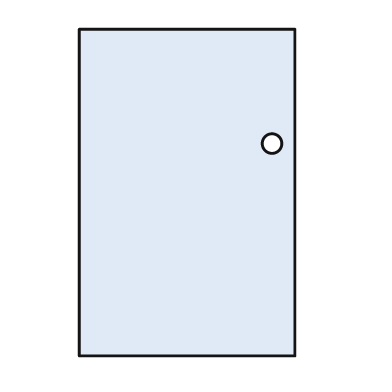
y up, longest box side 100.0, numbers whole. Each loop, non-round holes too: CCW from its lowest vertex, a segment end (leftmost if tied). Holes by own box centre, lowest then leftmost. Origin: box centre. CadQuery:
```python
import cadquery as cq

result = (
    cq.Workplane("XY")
    .moveTo(-33.0, -50.0)
    .lineTo(33.0, -50.0)
    .lineTo(33.0, 50.0)
    .lineTo(-33.0, 50.0)
    .close()
    .moveTo(26.0, 15.0)
    .circle(3.0)
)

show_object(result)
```